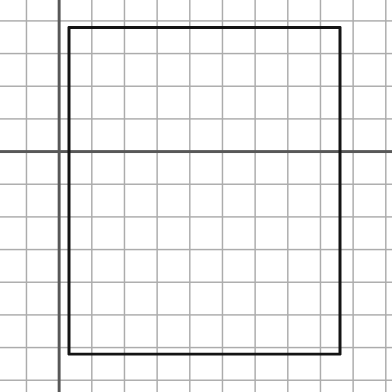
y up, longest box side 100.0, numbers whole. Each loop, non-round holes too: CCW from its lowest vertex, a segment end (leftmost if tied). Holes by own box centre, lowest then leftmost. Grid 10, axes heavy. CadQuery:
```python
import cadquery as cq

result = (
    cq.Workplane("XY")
    .moveTo(3.0, -62.0)
    .lineTo(86.0, -62.0)
    .lineTo(86.0, 38.0)
    .lineTo(3.0, 38.0)
    .close()
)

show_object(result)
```